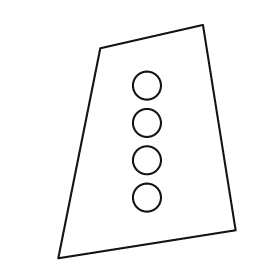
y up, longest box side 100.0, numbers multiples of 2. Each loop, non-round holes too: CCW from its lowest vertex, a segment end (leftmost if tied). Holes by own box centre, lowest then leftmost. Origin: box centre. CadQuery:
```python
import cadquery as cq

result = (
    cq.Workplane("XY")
    .moveTo(-38.0, -50.0)
    .lineTo(38.0, -38.0)
    .lineTo(24.0, 50.0)
    .lineTo(-20.0, 40.0)
    .close()
    .moveTo(0.0, -24.0)
    .circle(6.0)
    .moveTo(0.0, -8.0)
    .circle(6.0)
    .moveTo(0.0, 8.0)
    .circle(6.0)
    .moveTo(0.0, 24.0)
    .circle(6.0)
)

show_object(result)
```